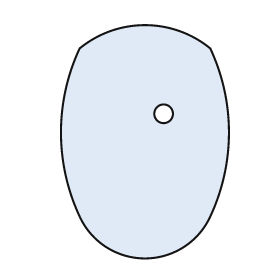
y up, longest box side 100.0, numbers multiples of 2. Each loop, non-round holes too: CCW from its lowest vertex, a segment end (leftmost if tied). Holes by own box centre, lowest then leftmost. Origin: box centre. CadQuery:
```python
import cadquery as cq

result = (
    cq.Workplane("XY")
    .moveTo(-28.0, -32.0)
    .threePointArc((0.0, -50.0), (28.0, -32.0))
    .threePointArc((36.0, 4.0), (28.0, 40.0))
    .threePointArc((0.0, 50.0), (-28.0, 40.0))
    .threePointArc((-36.0, 4.0), (-28.0, -32.0))
    .close()
    .moveTo(8.0, 12.0)
    .circle(4.0)
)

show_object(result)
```